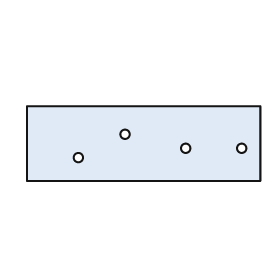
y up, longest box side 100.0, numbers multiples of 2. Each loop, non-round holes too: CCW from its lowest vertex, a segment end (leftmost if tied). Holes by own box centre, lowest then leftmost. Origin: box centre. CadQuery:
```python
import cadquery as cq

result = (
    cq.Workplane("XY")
    .moveTo(-50.0, -16.0)
    .lineTo(50.0, -16.0)
    .lineTo(50.0, 16.0)
    .lineTo(-50.0, 16.0)
    .close()
    .moveTo(-28.0, -6.0)
    .circle(2.0)
    .moveTo(18.0, -2.0)
    .circle(2.0)
    .moveTo(42.0, -2.0)
    .circle(2.0)
    .moveTo(-8.0, 4.0)
    .circle(2.0)
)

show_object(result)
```